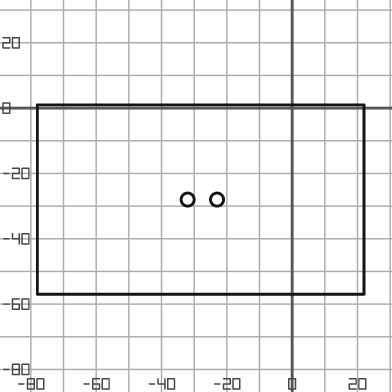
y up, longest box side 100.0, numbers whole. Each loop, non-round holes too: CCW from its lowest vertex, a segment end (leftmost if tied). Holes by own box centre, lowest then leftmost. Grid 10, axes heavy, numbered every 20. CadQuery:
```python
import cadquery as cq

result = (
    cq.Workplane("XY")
    .moveTo(-78.0, -57.0)
    .lineTo(22.0, -57.0)
    .lineTo(22.0, 1.0)
    .lineTo(-78.0, 1.0)
    .close()
    .moveTo(-32.0, -28.0)
    .circle(2.0)
    .moveTo(-23.0, -28.0)
    .circle(2.0)
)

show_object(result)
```